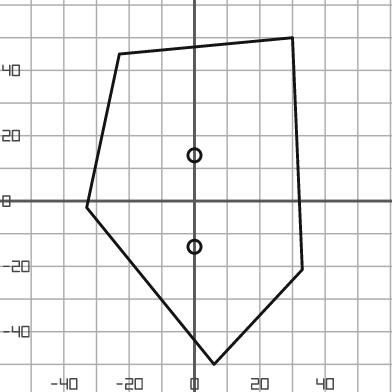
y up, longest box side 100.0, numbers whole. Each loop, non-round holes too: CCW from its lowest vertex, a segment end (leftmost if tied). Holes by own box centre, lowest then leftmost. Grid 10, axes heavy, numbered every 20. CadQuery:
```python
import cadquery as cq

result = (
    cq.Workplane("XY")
    .moveTo(6.0, -50.0)
    .lineTo(33.0, -21.0)
    .lineTo(30.0, 50.0)
    .lineTo(-23.0, 45.0)
    .lineTo(-33.0, -2.0)
    .close()
    .moveTo(0.0, -14.0)
    .circle(2.0)
    .moveTo(0.0, 14.0)
    .circle(2.0)
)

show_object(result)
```